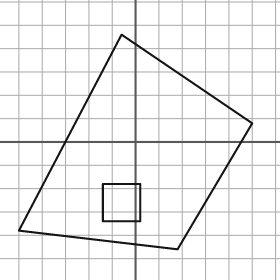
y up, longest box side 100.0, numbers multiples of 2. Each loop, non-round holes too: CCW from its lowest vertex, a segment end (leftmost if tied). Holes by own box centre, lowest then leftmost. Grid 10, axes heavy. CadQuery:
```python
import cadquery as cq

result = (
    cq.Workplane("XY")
    .moveTo(18.0, -46.0)
    .lineTo(50.0, 8.0)
    .lineTo(-6.0, 46.0)
    .lineTo(-50.0, -38.0)
    .close()
    .moveTo(-14.0, -34.0)
    .lineTo(2.0, -34.0)
    .lineTo(2.0, -18.0)
    .lineTo(-14.0, -18.0)
    .close()
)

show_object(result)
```